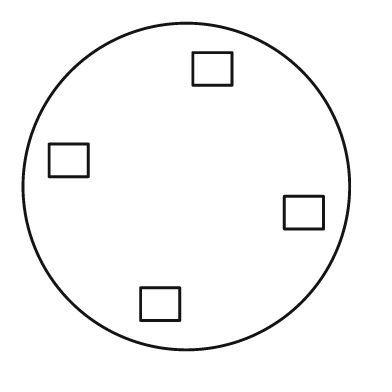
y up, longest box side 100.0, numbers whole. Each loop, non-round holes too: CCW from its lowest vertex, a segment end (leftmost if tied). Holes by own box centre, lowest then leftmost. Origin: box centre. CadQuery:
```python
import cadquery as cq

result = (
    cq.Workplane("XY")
    .moveTo(0.0, 0.0)
    .circle(50.0)
    .moveTo(-14.0, -41.0)
    .lineTo(-2.0, -41.0)
    .lineTo(-2.0, -31.0)
    .lineTo(-14.0, -31.0)
    .close()
    .moveTo(30.0, -13.0)
    .lineTo(42.0, -13.0)
    .lineTo(42.0, -3.0)
    .lineTo(30.0, -3.0)
    .close()
    .moveTo(-42.0, 3.0)
    .lineTo(-30.0, 3.0)
    .lineTo(-30.0, 13.0)
    .lineTo(-42.0, 13.0)
    .close()
    .moveTo(2.0, 31.0)
    .lineTo(14.0, 31.0)
    .lineTo(14.0, 41.0)
    .lineTo(2.0, 41.0)
    .close()
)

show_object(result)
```